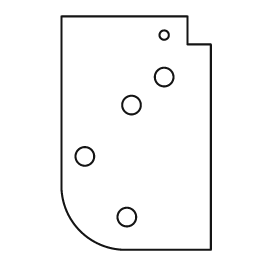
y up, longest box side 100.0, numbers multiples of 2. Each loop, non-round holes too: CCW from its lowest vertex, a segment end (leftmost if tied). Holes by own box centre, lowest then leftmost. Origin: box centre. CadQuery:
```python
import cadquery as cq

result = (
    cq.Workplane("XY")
    .moveTo(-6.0, -50.0)
    .lineTo(32.0, -50.0)
    .lineTo(32.0, 38.0)
    .lineTo(22.0, 38.0)
    .lineTo(22.0, 50.0)
    .lineTo(-32.0, 50.0)
    .lineTo(-32.0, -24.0)
    .threePointArc((-24.0, -42.0), (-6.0, -50.0))
    .close()
    .moveTo(-4.0, -36.0)
    .circle(4.0)
    .moveTo(-22.0, -10.0)
    .circle(4.0)
    .moveTo(-2.0, 12.0)
    .circle(4.0)
    .moveTo(12.0, 24.0)
    .circle(4.0)
    .moveTo(12.0, 42.0)
    .circle(2.0)
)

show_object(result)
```